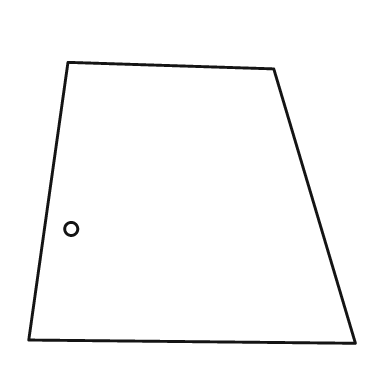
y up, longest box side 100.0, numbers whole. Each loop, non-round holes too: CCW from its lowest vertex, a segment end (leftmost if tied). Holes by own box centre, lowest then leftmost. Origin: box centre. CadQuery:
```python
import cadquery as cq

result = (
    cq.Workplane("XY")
    .moveTo(50.0, -43.0)
    .lineTo(25.0, 41.0)
    .lineTo(-38.0, 43.0)
    .lineTo(-50.0, -42.0)
    .close()
    .moveTo(-37.0, -8.0)
    .circle(2.0)
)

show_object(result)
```